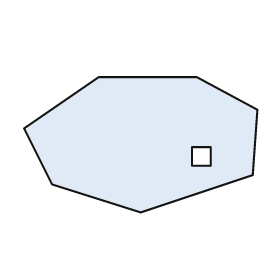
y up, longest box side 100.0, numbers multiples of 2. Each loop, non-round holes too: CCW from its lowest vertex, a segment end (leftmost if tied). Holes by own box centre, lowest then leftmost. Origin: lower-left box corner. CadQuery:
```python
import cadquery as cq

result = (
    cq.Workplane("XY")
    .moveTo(50.0, 0.0)
    .lineTo(98.0, 16.0)
    .lineTo(100.0, 44.0)
    .lineTo(74.0, 58.0)
    .lineTo(32.0, 58.0)
    .lineTo(0.0, 36.0)
    .lineTo(12.0, 12.0)
    .close()
    .moveTo(72.0, 20.0)
    .lineTo(80.0, 20.0)
    .lineTo(80.0, 28.0)
    .lineTo(72.0, 28.0)
    .close()
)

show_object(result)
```